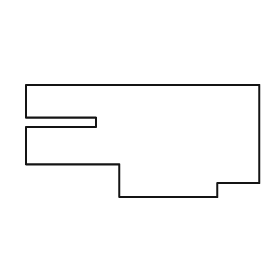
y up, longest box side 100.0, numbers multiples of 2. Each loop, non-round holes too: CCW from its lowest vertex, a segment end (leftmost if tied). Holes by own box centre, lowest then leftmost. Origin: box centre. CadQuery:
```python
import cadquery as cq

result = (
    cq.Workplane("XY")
    .moveTo(-10.0, -24.0)
    .lineTo(32.0, -24.0)
    .lineTo(32.0, -18.0)
    .lineTo(50.0, -18.0)
    .lineTo(50.0, 24.0)
    .lineTo(-50.0, 24.0)
    .lineTo(-50.0, 10.0)
    .lineTo(-20.0, 10.0)
    .lineTo(-20.0, 6.0)
    .lineTo(-50.0, 6.0)
    .lineTo(-50.0, -10.0)
    .lineTo(-10.0, -10.0)
    .close()
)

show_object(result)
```